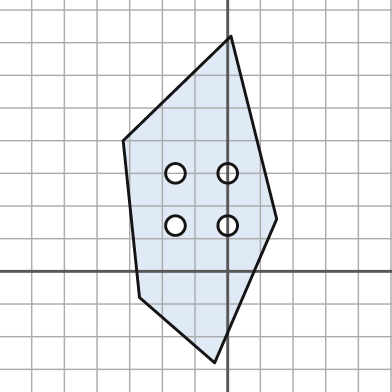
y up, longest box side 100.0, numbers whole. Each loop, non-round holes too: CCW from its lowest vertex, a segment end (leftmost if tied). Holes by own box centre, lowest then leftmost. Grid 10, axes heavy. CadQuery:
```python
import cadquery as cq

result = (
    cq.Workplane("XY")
    .moveTo(-4.0, -28.0)
    .lineTo(15.0, 16.0)
    .lineTo(1.0, 72.0)
    .lineTo(-32.0, 40.0)
    .lineTo(-27.0, -8.0)
    .close()
    .moveTo(-16.0, 14.0)
    .circle(3.0)
    .moveTo(0.0, 14.0)
    .circle(3.0)
    .moveTo(-16.0, 30.0)
    .circle(3.0)
    .moveTo(0.0, 30.0)
    .circle(3.0)
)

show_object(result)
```